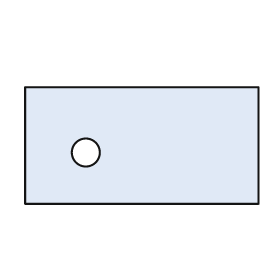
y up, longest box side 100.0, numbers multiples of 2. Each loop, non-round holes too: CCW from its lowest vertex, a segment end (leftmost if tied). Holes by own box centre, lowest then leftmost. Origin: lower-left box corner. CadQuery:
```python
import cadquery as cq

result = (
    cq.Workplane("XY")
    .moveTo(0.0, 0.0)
    .lineTo(100.0, 0.0)
    .lineTo(100.0, 50.0)
    .lineTo(0.0, 50.0)
    .close()
    .moveTo(26.0, 22.0)
    .circle(6.0)
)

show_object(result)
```